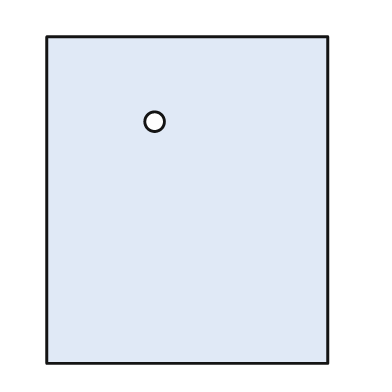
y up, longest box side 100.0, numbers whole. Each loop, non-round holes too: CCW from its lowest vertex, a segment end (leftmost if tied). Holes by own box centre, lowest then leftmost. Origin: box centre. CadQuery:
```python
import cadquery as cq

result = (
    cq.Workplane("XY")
    .moveTo(-43.0, -50.0)
    .lineTo(43.0, -50.0)
    .lineTo(43.0, 50.0)
    .lineTo(-43.0, 50.0)
    .close()
    .moveTo(-10.0, 24.0)
    .circle(3.0)
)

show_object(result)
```